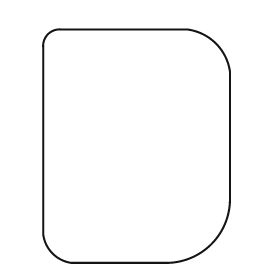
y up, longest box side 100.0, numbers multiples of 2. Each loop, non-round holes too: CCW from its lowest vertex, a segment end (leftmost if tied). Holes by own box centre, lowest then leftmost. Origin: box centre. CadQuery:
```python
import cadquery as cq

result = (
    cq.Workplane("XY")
    .moveTo(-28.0, -50.0)
    .lineTo(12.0, -50.0)
    .threePointArc((32.0, -42.0), (40.0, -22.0))
    .lineTo(40.0, 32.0)
    .threePointArc((34.0, 44.0), (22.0, 50.0))
    .lineTo(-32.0, 50.0)
    .threePointArc((-38.0, 48.0), (-40.0, 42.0))
    .lineTo(-40.0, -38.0)
    .threePointArc((-36.0, -46.0), (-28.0, -50.0))
    .close()
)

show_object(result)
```